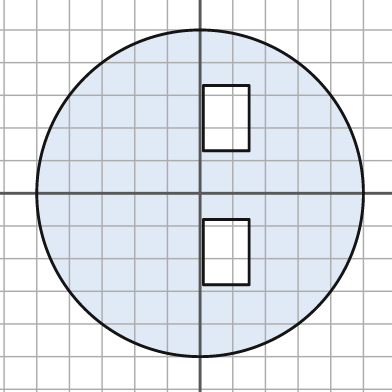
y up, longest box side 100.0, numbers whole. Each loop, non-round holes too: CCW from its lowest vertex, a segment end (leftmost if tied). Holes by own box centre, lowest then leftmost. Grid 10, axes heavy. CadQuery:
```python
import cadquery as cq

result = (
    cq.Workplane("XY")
    .moveTo(0.0, 0.0)
    .circle(50.0)
    .moveTo(1.0, -28.0)
    .lineTo(15.0, -28.0)
    .lineTo(15.0, -8.0)
    .lineTo(1.0, -8.0)
    .close()
    .moveTo(1.0, 13.0)
    .lineTo(15.0, 13.0)
    .lineTo(15.0, 33.0)
    .lineTo(1.0, 33.0)
    .close()
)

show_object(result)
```